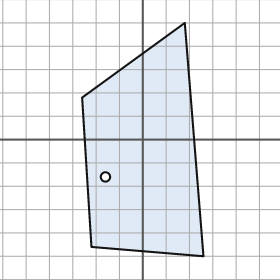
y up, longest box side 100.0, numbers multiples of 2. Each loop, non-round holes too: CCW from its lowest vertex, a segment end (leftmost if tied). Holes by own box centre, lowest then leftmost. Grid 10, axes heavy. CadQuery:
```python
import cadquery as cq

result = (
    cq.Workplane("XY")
    .moveTo(26.0, -50.0)
    .lineTo(18.0, 50.0)
    .lineTo(-26.0, 18.0)
    .lineTo(-22.0, -46.0)
    .close()
    .moveTo(-16.0, -16.0)
    .circle(2.0)
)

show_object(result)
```